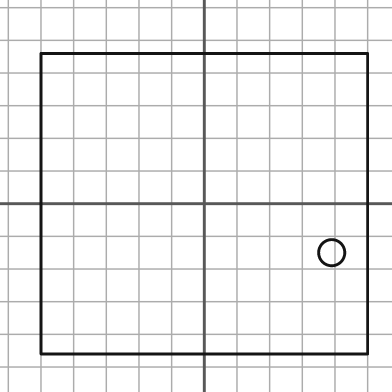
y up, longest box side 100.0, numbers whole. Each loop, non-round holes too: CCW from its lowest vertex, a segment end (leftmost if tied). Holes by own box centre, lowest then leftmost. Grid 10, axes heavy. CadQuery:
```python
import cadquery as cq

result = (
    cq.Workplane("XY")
    .moveTo(-50.0, -46.0)
    .lineTo(50.0, -46.0)
    .lineTo(50.0, 46.0)
    .lineTo(-50.0, 46.0)
    .close()
    .moveTo(39.0, -15.0)
    .circle(4.0)
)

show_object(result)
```